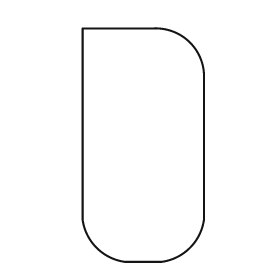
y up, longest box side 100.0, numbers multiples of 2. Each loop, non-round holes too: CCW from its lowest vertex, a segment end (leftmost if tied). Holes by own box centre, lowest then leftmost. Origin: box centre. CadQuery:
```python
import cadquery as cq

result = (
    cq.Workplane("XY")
    .moveTo(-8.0, -50.0)
    .lineTo(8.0, -50.0)
    .threePointArc((20.0, -44.0), (26.0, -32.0))
    .lineTo(26.0, 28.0)
    .threePointArc((20.0, 44.0), (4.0, 50.0))
    .lineTo(-26.0, 50.0)
    .lineTo(-26.0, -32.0)
    .threePointArc((-20.0, -44.0), (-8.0, -50.0))
    .close()
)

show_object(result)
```